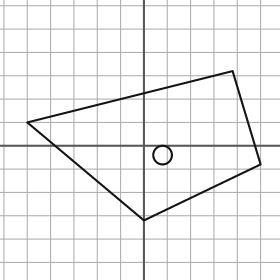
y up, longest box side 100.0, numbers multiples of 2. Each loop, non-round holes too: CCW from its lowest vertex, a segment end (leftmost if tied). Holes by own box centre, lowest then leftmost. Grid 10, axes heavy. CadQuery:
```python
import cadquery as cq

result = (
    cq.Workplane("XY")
    .moveTo(0.0, -32.0)
    .lineTo(50.0, -8.0)
    .lineTo(38.0, 32.0)
    .lineTo(-50.0, 10.0)
    .close()
    .moveTo(8.0, -4.0)
    .circle(4.0)
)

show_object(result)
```